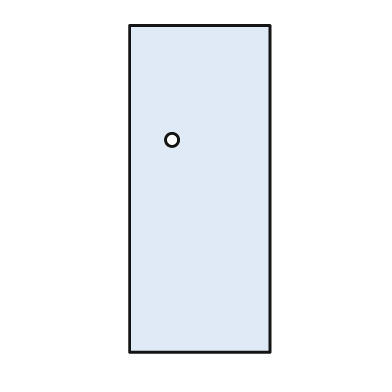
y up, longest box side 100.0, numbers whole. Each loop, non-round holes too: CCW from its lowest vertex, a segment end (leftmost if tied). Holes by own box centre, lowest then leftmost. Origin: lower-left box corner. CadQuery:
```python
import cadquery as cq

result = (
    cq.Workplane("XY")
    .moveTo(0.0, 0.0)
    .lineTo(43.0, 0.0)
    .lineTo(43.0, 100.0)
    .lineTo(0.0, 100.0)
    .close()
    .moveTo(13.0, 65.0)
    .circle(2.0)
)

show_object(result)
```